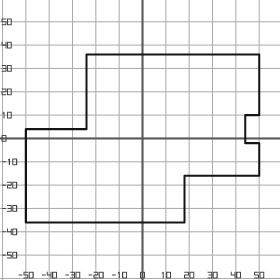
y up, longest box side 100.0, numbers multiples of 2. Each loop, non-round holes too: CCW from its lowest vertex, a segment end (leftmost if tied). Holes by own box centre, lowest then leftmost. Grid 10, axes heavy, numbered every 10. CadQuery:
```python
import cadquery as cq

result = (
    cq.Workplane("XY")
    .moveTo(-50.0, -36.0)
    .lineTo(18.0, -36.0)
    .lineTo(18.0, -16.0)
    .lineTo(50.0, -16.0)
    .lineTo(50.0, -2.0)
    .lineTo(44.0, -2.0)
    .lineTo(44.0, 10.0)
    .lineTo(50.0, 10.0)
    .lineTo(50.0, 36.0)
    .lineTo(-24.0, 36.0)
    .lineTo(-24.0, 4.0)
    .lineTo(-50.0, 4.0)
    .close()
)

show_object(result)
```